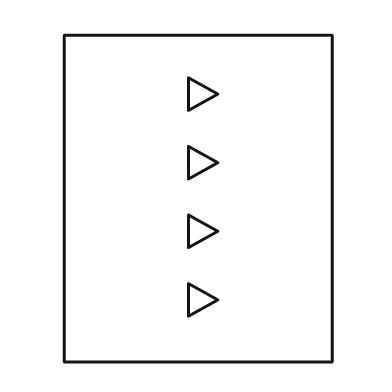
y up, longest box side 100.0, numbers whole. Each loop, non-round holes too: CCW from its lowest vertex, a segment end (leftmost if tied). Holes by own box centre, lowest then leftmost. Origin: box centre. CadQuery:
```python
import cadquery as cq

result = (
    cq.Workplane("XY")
    .moveTo(-41.0, -50.0)
    .lineTo(41.0, -50.0)
    .lineTo(41.0, 50.0)
    .lineTo(-41.0, 50.0)
    .close()
    .moveTo(-3.0, -36.0)
    .lineTo(6.0, -31.0)
    .lineTo(-3.0, -26.0)
    .close()
    .moveTo(-3.0, -15.0)
    .lineTo(6.0, -10.0)
    .lineTo(-3.0, -5.0)
    .close()
    .moveTo(-3.0, 6.0)
    .lineTo(6.0, 11.0)
    .lineTo(-3.0, 16.0)
    .close()
    .moveTo(-3.0, 27.0)
    .lineTo(6.0, 32.0)
    .lineTo(-3.0, 37.0)
    .close()
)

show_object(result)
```